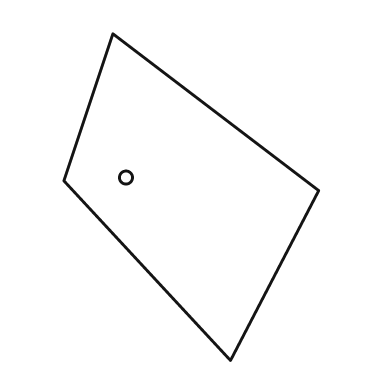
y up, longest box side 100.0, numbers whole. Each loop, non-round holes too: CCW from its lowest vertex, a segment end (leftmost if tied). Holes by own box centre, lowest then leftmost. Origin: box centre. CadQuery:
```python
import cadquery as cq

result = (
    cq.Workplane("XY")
    .moveTo(12.0, -50.0)
    .lineTo(39.0, 2.0)
    .lineTo(-24.0, 50.0)
    .lineTo(-39.0, 5.0)
    .close()
    .moveTo(-20.0, 6.0)
    .circle(2.0)
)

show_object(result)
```